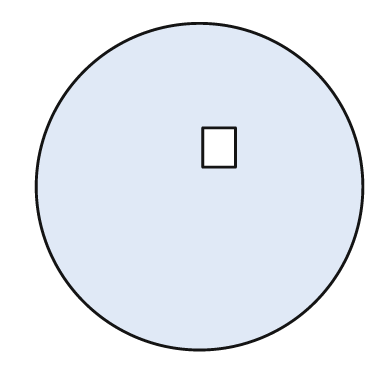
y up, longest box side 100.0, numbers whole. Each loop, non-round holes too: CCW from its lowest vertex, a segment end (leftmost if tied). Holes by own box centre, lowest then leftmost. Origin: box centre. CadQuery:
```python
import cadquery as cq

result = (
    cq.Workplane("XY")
    .moveTo(0.0, 0.0)
    .circle(50.0)
    .moveTo(1.0, 6.0)
    .lineTo(11.0, 6.0)
    .lineTo(11.0, 18.0)
    .lineTo(1.0, 18.0)
    .close()
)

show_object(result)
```